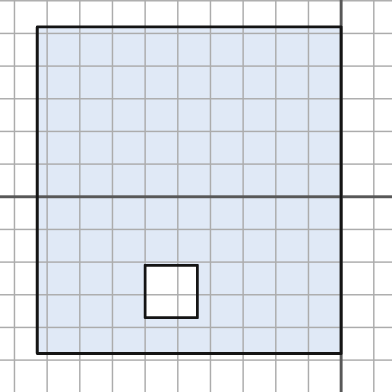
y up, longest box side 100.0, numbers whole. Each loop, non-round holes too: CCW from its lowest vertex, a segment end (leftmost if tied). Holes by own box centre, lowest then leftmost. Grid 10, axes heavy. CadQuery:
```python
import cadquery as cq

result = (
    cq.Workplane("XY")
    .moveTo(-93.0, -48.0)
    .lineTo(0.0, -48.0)
    .lineTo(0.0, 52.0)
    .lineTo(-93.0, 52.0)
    .close()
    .moveTo(-60.0, -37.0)
    .lineTo(-44.0, -37.0)
    .lineTo(-44.0, -21.0)
    .lineTo(-60.0, -21.0)
    .close()
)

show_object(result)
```